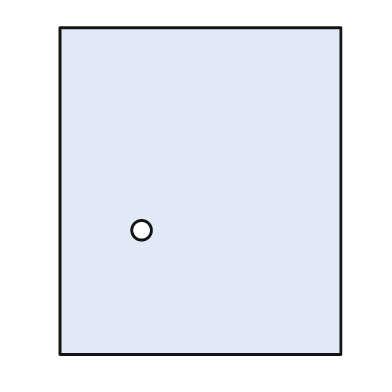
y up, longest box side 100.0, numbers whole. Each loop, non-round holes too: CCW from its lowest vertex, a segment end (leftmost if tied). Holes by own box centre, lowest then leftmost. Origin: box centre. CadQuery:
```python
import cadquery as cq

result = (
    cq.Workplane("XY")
    .moveTo(-43.0, -50.0)
    .lineTo(43.0, -50.0)
    .lineTo(43.0, 50.0)
    .lineTo(-43.0, 50.0)
    .close()
    .moveTo(-18.0, -12.0)
    .circle(3.0)
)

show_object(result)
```